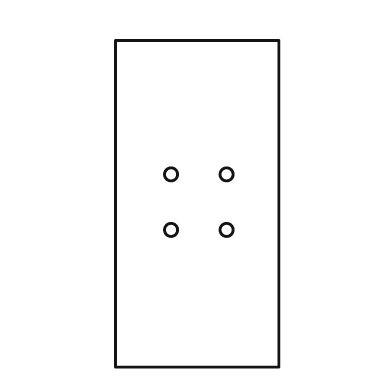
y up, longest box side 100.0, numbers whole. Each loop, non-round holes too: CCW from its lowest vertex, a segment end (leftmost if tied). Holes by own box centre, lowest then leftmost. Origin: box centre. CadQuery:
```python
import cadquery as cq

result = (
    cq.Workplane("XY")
    .moveTo(-25.0, -50.0)
    .lineTo(25.0, -50.0)
    .lineTo(25.0, 50.0)
    .lineTo(-25.0, 50.0)
    .close()
    .moveTo(-8.0, -8.0)
    .circle(2.0)
    .moveTo(9.0, -8.0)
    .circle(2.0)
    .moveTo(-8.0, 9.0)
    .circle(2.0)
    .moveTo(9.0, 9.0)
    .circle(2.0)
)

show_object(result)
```